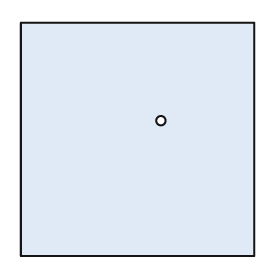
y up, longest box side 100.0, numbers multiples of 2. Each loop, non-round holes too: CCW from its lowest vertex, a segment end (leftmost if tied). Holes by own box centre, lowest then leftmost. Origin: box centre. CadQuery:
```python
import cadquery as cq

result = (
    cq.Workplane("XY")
    .moveTo(-50.0, -50.0)
    .lineTo(50.0, -50.0)
    .lineTo(50.0, 50.0)
    .lineTo(-50.0, 50.0)
    .close()
    .moveTo(10.0, 8.0)
    .circle(2.0)
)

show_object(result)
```